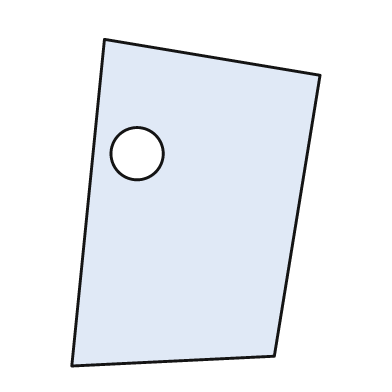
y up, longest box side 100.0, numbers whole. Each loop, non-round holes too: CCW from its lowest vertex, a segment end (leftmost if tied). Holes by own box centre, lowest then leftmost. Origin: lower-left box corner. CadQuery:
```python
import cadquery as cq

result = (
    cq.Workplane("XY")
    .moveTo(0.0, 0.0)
    .lineTo(62.0, 3.0)
    .lineTo(76.0, 89.0)
    .lineTo(10.0, 100.0)
    .close()
    .moveTo(20.0, 65.0)
    .circle(8.0)
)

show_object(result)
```